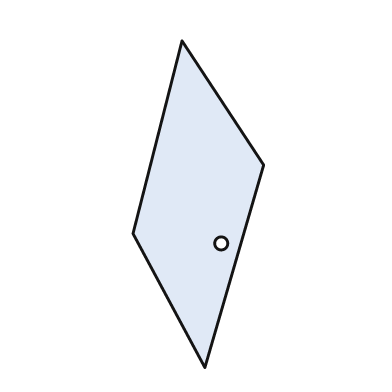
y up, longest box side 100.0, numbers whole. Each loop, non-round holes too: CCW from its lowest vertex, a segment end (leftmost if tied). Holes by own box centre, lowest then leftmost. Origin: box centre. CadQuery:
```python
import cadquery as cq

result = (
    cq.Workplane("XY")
    .moveTo(2.0, -50.0)
    .lineTo(20.0, 12.0)
    .lineTo(-5.0, 50.0)
    .lineTo(-20.0, -9.0)
    .close()
    .moveTo(7.0, -12.0)
    .circle(2.0)
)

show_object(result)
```